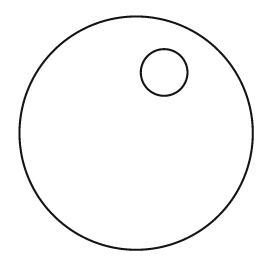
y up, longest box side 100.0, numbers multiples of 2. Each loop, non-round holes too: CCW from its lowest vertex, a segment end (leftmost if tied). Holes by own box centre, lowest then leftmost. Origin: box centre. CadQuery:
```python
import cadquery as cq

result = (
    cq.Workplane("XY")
    .moveTo(0.0, 0.0)
    .circle(50.0)
    .moveTo(12.0, 26.0)
    .circle(10.0)
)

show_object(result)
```